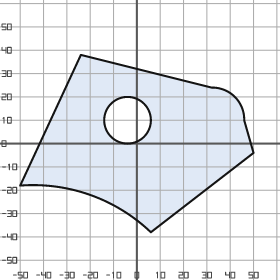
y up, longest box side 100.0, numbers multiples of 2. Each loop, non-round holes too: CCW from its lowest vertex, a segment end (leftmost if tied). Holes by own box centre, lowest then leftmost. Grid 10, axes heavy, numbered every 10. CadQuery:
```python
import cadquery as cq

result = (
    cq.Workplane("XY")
    .moveTo(6.0, -38.0)
    .lineTo(50.0, -4.0)
    .lineTo(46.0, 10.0)
    .threePointArc((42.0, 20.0), (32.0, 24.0))
    .lineTo(-24.0, 38.0)
    .lineTo(-50.0, -18.0)
    .threePointArc((-20.0, -22.0), (6.0, -38.0))
    .close()
    .moveTo(-4.0, 10.0)
    .circle(10.0)
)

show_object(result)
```